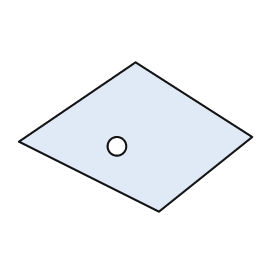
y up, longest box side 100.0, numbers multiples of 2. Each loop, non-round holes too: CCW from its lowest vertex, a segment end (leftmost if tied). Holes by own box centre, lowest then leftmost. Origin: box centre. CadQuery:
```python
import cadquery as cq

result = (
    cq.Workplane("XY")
    .moveTo(10.0, -32.0)
    .lineTo(50.0, 0.0)
    .lineTo(0.0, 32.0)
    .lineTo(-50.0, -2.0)
    .close()
    .moveTo(-8.0, -4.0)
    .circle(4.0)
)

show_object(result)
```